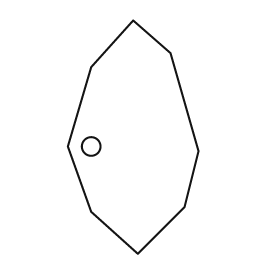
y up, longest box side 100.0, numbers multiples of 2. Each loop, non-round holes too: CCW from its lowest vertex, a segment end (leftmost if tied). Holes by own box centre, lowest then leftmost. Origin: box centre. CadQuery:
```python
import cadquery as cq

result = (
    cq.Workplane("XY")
    .moveTo(2.0, -50.0)
    .lineTo(22.0, -30.0)
    .lineTo(28.0, -6.0)
    .lineTo(16.0, 36.0)
    .lineTo(0.0, 50.0)
    .lineTo(-18.0, 30.0)
    .lineTo(-28.0, -4.0)
    .lineTo(-18.0, -32.0)
    .close()
    .moveTo(-18.0, -4.0)
    .circle(4.0)
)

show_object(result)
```